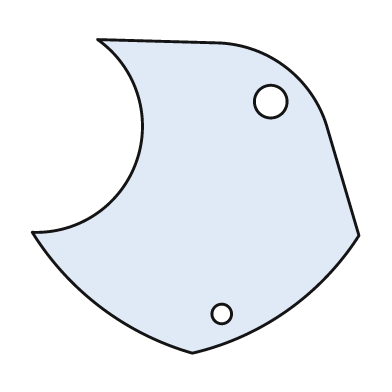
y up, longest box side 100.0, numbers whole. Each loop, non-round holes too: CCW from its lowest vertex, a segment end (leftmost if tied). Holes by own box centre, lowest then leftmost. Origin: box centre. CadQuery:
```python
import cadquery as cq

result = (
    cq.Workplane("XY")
    .moveTo(-1.0, -48.0)
    .threePointArc((28.0, -35.0), (50.0, -12.0))
    .lineTo(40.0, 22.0)
    .threePointArc((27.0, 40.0), (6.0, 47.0))
    .lineTo(-30.0, 48.0)
    .threePointArc((-18.0, 11.0), (-50.0, -11.0))
    .threePointArc((-29.0, -34.0), (-1.0, -48.0))
    .close()
    .moveTo(8.0, -36.0)
    .circle(3.0)
    .moveTo(23.0, 29.0)
    .circle(5.0)
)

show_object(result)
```